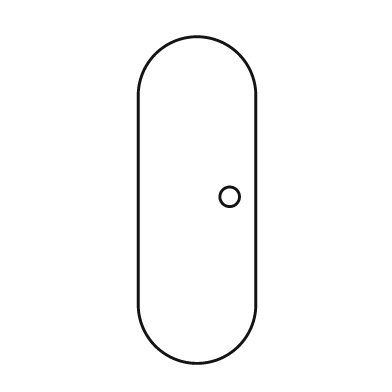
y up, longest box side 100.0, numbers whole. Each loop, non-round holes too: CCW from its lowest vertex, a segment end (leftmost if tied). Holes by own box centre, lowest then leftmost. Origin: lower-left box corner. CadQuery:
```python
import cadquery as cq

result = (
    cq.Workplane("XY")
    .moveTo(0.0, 18.0)
    .threePointArc((18.0, 0.0), (36.0, 18.0))
    .lineTo(36.0, 82.0)
    .threePointArc((18.0, 100.0), (0.0, 82.0))
    .close()
    .moveTo(28.0, 51.0)
    .circle(3.0)
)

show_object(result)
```